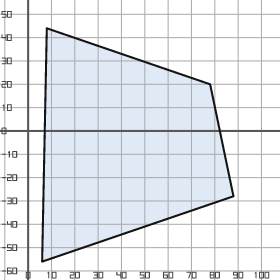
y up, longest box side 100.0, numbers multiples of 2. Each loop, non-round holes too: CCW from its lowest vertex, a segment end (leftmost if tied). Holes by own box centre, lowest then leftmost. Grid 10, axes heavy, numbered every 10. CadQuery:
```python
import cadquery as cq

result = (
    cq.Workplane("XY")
    .moveTo(6.0, -56.0)
    .lineTo(88.0, -28.0)
    .lineTo(78.0, 20.0)
    .lineTo(8.0, 44.0)
    .close()
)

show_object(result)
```